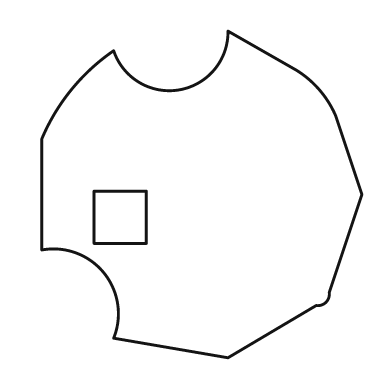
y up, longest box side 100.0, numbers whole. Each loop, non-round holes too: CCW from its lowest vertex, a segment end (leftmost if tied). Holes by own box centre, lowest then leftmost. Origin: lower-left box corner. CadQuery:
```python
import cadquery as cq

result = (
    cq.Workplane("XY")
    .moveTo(57.0, 0.0)
    .lineTo(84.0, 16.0)
    .threePointArc((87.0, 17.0), (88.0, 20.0))
    .lineTo(98.0, 50.0)
    .lineTo(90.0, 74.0)
    .threePointArc((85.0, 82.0), (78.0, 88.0))
    .lineTo(57.0, 100.0)
    .threePointArc((42.0, 82.0), (22.0, 94.0))
    .threePointArc((9.0, 82.0), (0.0, 67.0))
    .lineTo(0.0, 33.0)
    .threePointArc((19.0, 26.0), (22.0, 6.0))
    .close()
    .moveTo(16.0, 35.0)
    .lineTo(32.0, 35.0)
    .lineTo(32.0, 51.0)
    .lineTo(16.0, 51.0)
    .close()
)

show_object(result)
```